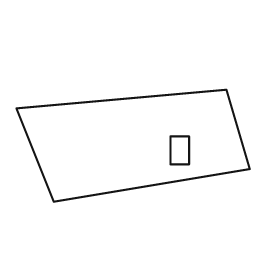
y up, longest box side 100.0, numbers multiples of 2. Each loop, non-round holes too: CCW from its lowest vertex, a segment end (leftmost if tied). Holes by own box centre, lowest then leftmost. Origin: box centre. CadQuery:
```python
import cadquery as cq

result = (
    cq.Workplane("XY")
    .moveTo(-34.0, -24.0)
    .lineTo(50.0, -10.0)
    .lineTo(40.0, 24.0)
    .lineTo(-50.0, 16.0)
    .close()
    .moveTo(16.0, -8.0)
    .lineTo(24.0, -8.0)
    .lineTo(24.0, 4.0)
    .lineTo(16.0, 4.0)
    .close()
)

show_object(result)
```